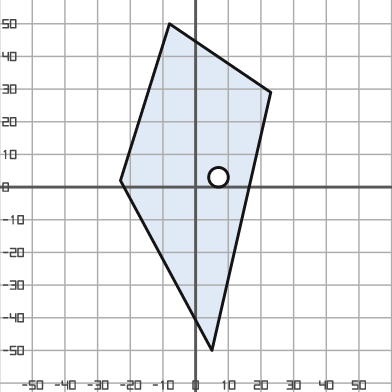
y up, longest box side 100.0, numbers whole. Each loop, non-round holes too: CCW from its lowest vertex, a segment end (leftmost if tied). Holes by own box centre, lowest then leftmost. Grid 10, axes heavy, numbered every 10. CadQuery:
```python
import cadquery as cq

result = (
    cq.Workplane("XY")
    .moveTo(5.0, -50.0)
    .lineTo(23.0, 29.0)
    .lineTo(-8.0, 50.0)
    .lineTo(-23.0, 2.0)
    .close()
    .moveTo(7.0, 3.0)
    .circle(3.0)
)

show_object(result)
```